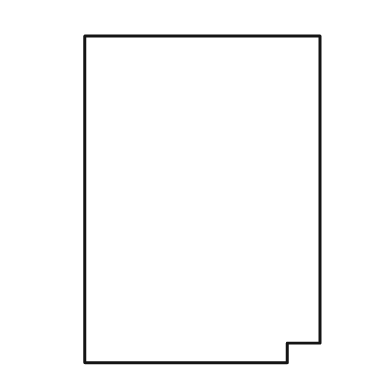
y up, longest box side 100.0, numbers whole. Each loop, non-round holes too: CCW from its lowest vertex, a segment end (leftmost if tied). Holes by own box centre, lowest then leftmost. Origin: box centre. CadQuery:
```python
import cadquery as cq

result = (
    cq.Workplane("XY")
    .moveTo(-36.0, -50.0)
    .lineTo(26.0, -50.0)
    .lineTo(26.0, -44.0)
    .lineTo(36.0, -44.0)
    .lineTo(36.0, 50.0)
    .lineTo(-36.0, 50.0)
    .close()
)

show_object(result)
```